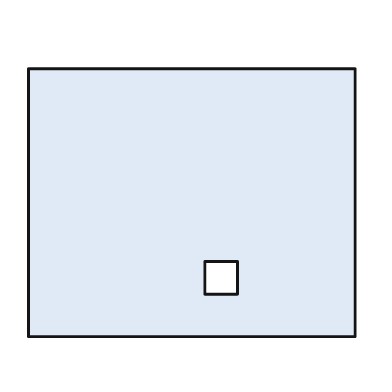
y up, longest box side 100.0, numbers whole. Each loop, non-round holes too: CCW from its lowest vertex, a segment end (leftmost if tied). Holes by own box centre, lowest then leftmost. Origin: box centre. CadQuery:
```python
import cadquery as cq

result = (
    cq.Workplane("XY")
    .moveTo(-50.0, -41.0)
    .lineTo(50.0, -41.0)
    .lineTo(50.0, 41.0)
    .lineTo(-50.0, 41.0)
    .close()
    .moveTo(4.0, -28.0)
    .lineTo(14.0, -28.0)
    .lineTo(14.0, -18.0)
    .lineTo(4.0, -18.0)
    .close()
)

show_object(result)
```